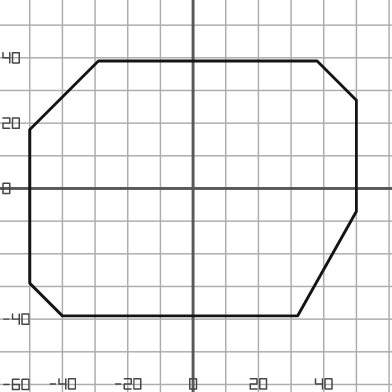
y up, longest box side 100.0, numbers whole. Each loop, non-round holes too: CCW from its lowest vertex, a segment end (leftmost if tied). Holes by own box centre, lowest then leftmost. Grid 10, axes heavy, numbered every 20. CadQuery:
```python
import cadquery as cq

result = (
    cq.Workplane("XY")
    .moveTo(-40.0, -39.0)
    .lineTo(32.0, -39.0)
    .lineTo(50.0, -7.0)
    .lineTo(50.0, 27.0)
    .lineTo(38.0, 39.0)
    .lineTo(-29.0, 39.0)
    .lineTo(-50.0, 18.0)
    .lineTo(-50.0, -29.0)
    .close()
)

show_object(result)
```